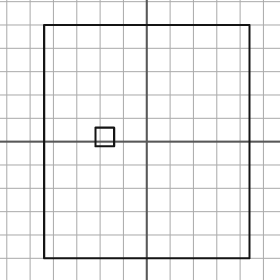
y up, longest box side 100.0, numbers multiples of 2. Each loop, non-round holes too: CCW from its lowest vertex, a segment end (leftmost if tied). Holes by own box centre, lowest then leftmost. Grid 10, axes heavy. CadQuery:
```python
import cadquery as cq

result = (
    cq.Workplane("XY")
    .moveTo(-44.0, -50.0)
    .lineTo(44.0, -50.0)
    .lineTo(44.0, 50.0)
    .lineTo(-44.0, 50.0)
    .close()
    .moveTo(-22.0, -2.0)
    .lineTo(-14.0, -2.0)
    .lineTo(-14.0, 6.0)
    .lineTo(-22.0, 6.0)
    .close()
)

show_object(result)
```